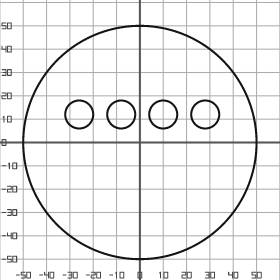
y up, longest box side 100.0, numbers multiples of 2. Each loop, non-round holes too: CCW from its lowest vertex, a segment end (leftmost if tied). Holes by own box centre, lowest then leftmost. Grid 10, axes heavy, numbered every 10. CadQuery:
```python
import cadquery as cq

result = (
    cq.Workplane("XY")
    .moveTo(0.0, 0.0)
    .circle(50.0)
    .moveTo(-26.0, 12.0)
    .circle(6.0)
    .moveTo(-8.0, 12.0)
    .circle(6.0)
    .moveTo(10.0, 12.0)
    .circle(6.0)
    .moveTo(28.0, 12.0)
    .circle(6.0)
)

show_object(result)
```